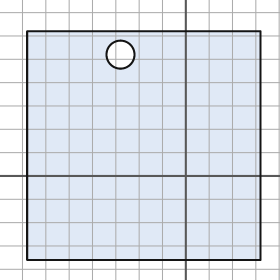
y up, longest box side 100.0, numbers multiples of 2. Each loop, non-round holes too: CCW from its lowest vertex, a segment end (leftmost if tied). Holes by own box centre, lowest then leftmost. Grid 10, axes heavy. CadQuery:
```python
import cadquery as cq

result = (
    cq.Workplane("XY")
    .moveTo(-68.0, -36.0)
    .lineTo(32.0, -36.0)
    .lineTo(32.0, 62.0)
    .lineTo(-68.0, 62.0)
    .close()
    .moveTo(-28.0, 52.0)
    .circle(6.0)
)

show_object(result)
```